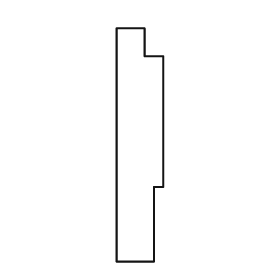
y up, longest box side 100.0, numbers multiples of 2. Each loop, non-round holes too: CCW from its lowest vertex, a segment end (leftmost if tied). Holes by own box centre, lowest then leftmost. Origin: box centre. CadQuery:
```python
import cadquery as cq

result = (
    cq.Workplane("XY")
    .moveTo(-10.0, -50.0)
    .lineTo(6.0, -50.0)
    .lineTo(6.0, -18.0)
    .lineTo(10.0, -18.0)
    .lineTo(10.0, 38.0)
    .lineTo(2.0, 38.0)
    .lineTo(2.0, 50.0)
    .lineTo(-10.0, 50.0)
    .close()
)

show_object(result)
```